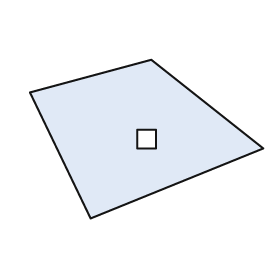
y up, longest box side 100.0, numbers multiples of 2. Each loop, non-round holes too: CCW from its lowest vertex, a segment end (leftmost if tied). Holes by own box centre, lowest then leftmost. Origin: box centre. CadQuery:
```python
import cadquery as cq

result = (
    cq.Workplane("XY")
    .moveTo(-24.0, -34.0)
    .lineTo(50.0, -4.0)
    .lineTo(2.0, 34.0)
    .lineTo(-50.0, 20.0)
    .close()
    .moveTo(-4.0, -4.0)
    .lineTo(4.0, -4.0)
    .lineTo(4.0, 4.0)
    .lineTo(-4.0, 4.0)
    .close()
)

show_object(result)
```